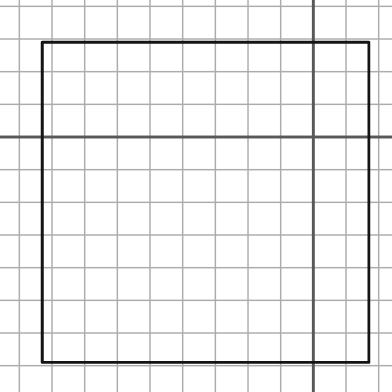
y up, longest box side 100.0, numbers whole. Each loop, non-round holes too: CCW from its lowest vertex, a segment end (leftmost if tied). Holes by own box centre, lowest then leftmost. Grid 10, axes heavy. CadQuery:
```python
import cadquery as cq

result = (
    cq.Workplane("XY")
    .moveTo(-83.0, -69.0)
    .lineTo(17.0, -69.0)
    .lineTo(17.0, 29.0)
    .lineTo(-83.0, 29.0)
    .close()
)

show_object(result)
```